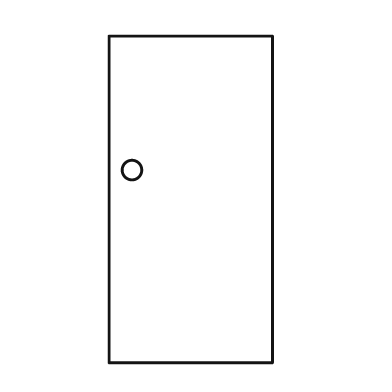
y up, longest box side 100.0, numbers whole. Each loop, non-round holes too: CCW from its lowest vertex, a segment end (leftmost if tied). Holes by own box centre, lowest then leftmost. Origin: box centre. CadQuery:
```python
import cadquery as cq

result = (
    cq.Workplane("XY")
    .moveTo(-25.0, -50.0)
    .lineTo(25.0, -50.0)
    .lineTo(25.0, 50.0)
    .lineTo(-25.0, 50.0)
    .close()
    .moveTo(-18.0, 9.0)
    .circle(3.0)
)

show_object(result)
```